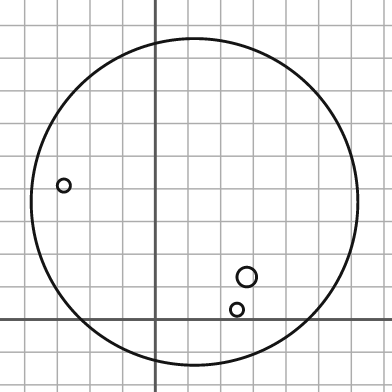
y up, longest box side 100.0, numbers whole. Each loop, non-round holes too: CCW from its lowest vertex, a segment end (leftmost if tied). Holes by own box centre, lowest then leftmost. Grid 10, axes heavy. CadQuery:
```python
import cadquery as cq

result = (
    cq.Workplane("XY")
    .moveTo(12.0, 36.0)
    .circle(50.0)
    .moveTo(25.0, 3.0)
    .circle(2.0)
    .moveTo(28.0, 13.0)
    .circle(3.0)
    .moveTo(-28.0, 41.0)
    .circle(2.0)
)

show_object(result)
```